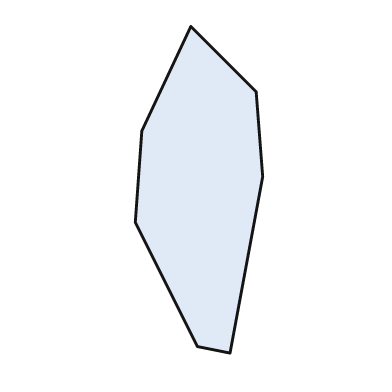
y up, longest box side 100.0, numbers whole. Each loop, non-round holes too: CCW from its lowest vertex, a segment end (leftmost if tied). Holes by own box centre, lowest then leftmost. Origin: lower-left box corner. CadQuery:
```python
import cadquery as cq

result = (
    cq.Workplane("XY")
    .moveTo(29.0, 0.0)
    .lineTo(39.0, 54.0)
    .lineTo(37.0, 80.0)
    .lineTo(17.0, 100.0)
    .lineTo(2.0, 68.0)
    .lineTo(0.0, 40.0)
    .lineTo(19.0, 2.0)
    .close()
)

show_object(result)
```